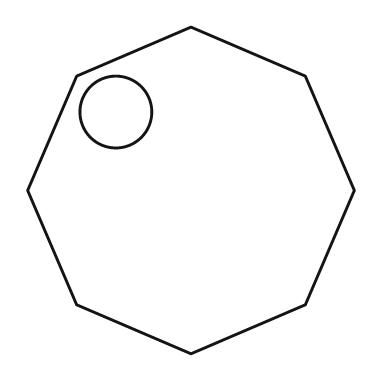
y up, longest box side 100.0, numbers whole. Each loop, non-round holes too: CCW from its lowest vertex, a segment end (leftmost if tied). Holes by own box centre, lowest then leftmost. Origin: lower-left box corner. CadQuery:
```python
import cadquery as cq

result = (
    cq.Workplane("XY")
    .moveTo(50.0, 0.0)
    .lineTo(85.0, 15.0)
    .lineTo(100.0, 50.0)
    .lineTo(85.0, 85.0)
    .lineTo(50.0, 100.0)
    .lineTo(15.0, 85.0)
    .lineTo(0.0, 50.0)
    .lineTo(15.0, 15.0)
    .close()
    .moveTo(27.0, 74.0)
    .circle(11.0)
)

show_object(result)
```